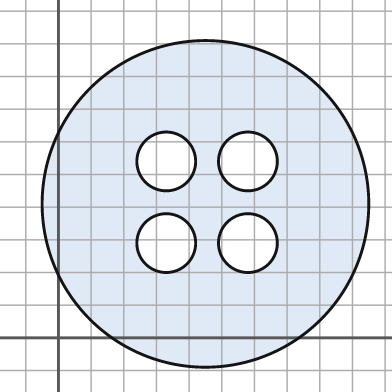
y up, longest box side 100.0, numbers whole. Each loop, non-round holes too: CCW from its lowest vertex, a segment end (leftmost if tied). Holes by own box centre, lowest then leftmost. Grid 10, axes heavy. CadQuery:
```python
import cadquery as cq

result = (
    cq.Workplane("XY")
    .moveTo(45.0, 41.0)
    .circle(50.0)
    .moveTo(33.0, 29.0)
    .circle(9.0)
    .moveTo(58.0, 29.0)
    .circle(9.0)
    .moveTo(33.0, 54.0)
    .circle(9.0)
    .moveTo(58.0, 54.0)
    .circle(9.0)
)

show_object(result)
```